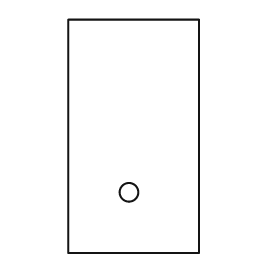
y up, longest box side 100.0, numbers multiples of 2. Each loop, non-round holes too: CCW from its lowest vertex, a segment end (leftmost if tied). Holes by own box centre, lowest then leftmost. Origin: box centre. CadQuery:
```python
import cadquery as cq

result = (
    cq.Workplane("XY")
    .moveTo(-28.0, -50.0)
    .lineTo(28.0, -50.0)
    .lineTo(28.0, 50.0)
    .lineTo(-28.0, 50.0)
    .close()
    .moveTo(-2.0, -24.0)
    .circle(4.0)
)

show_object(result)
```